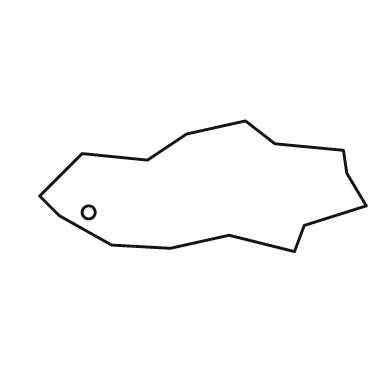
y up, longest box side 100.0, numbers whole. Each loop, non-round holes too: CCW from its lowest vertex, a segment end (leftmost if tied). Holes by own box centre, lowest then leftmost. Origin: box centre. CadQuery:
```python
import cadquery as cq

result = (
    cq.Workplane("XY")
    .moveTo(28.0, -20.0)
    .lineTo(31.0, -12.0)
    .lineTo(50.0, -6.0)
    .lineTo(44.0, 4.0)
    .lineTo(43.0, 11.0)
    .lineTo(22.0, 13.0)
    .lineTo(13.0, 20.0)
    .lineTo(-5.0, 16.0)
    .lineTo(-17.0, 8.0)
    .lineTo(-37.0, 10.0)
    .lineTo(-50.0, -3.0)
    .lineTo(-44.0, -9.0)
    .lineTo(-28.0, -18.0)
    .lineTo(-10.0, -19.0)
    .lineTo(8.0, -15.0)
    .close()
    .moveTo(-35.0, -8.0)
    .circle(2.0)
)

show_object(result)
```